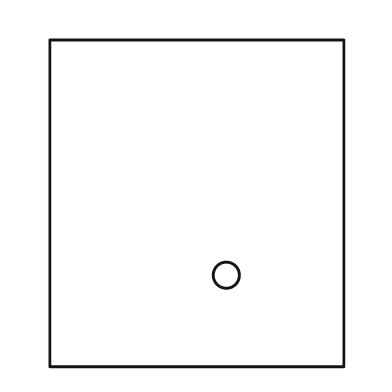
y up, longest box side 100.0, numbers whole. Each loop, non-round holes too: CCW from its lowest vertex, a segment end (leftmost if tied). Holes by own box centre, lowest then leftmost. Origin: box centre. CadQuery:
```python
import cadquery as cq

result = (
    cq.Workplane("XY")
    .moveTo(-45.0, -50.0)
    .lineTo(45.0, -50.0)
    .lineTo(45.0, 50.0)
    .lineTo(-45.0, 50.0)
    .close()
    .moveTo(9.0, -22.0)
    .circle(4.0)
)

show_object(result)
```